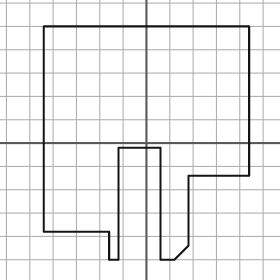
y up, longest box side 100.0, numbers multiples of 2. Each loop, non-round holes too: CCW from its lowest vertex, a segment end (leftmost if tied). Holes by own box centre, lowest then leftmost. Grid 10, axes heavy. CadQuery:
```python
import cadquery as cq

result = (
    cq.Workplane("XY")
    .moveTo(-16.0, -50.0)
    .lineTo(-12.0, -50.0)
    .lineTo(-12.0, -2.0)
    .lineTo(6.0, -2.0)
    .lineTo(6.0, -50.0)
    .lineTo(12.0, -50.0)
    .lineTo(18.0, -44.0)
    .lineTo(18.0, -14.0)
    .lineTo(44.0, -14.0)
    .lineTo(44.0, 50.0)
    .lineTo(-44.0, 50.0)
    .lineTo(-44.0, -38.0)
    .lineTo(-16.0, -38.0)
    .close()
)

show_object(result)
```